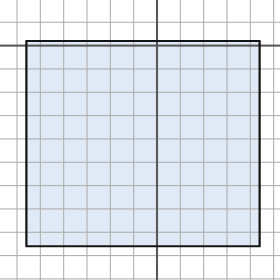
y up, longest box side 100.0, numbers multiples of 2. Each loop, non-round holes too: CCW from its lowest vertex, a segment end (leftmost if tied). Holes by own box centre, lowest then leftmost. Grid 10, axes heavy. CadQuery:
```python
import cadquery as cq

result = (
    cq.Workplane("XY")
    .moveTo(-56.0, -86.0)
    .lineTo(44.0, -86.0)
    .lineTo(44.0, 2.0)
    .lineTo(-56.0, 2.0)
    .close()
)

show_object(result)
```